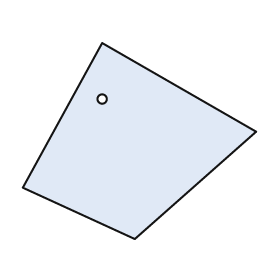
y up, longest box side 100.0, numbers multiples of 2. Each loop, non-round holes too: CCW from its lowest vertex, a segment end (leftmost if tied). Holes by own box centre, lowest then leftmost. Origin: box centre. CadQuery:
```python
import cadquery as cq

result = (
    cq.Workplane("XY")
    .moveTo(-2.0, -42.0)
    .lineTo(50.0, 4.0)
    .lineTo(-16.0, 42.0)
    .lineTo(-50.0, -20.0)
    .close()
    .moveTo(-16.0, 18.0)
    .circle(2.0)
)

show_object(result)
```